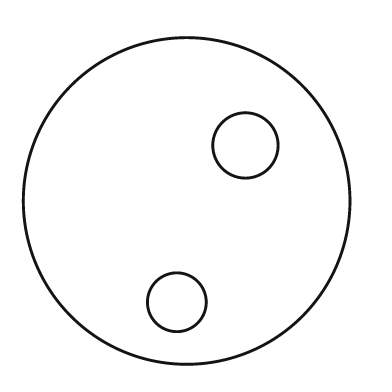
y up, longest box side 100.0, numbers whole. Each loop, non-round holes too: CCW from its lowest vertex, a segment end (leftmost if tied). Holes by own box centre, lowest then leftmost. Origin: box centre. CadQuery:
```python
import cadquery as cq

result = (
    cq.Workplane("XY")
    .moveTo(0.0, 0.0)
    .circle(50.0)
    .moveTo(-3.0, -31.0)
    .circle(9.0)
    .moveTo(18.0, 17.0)
    .circle(10.0)
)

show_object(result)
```